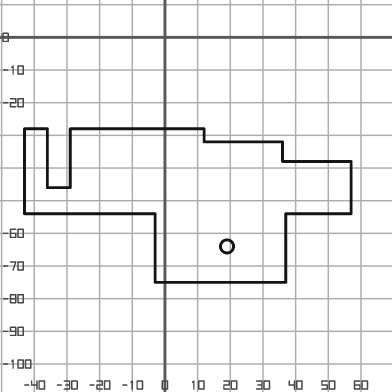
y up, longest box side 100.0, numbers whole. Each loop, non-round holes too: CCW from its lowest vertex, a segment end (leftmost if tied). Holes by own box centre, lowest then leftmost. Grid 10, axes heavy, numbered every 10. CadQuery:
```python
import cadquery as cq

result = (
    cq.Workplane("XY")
    .moveTo(-3.0, -75.0)
    .lineTo(37.0, -75.0)
    .lineTo(37.0, -54.0)
    .lineTo(57.0, -54.0)
    .lineTo(57.0, -38.0)
    .lineTo(36.0, -38.0)
    .lineTo(36.0, -32.0)
    .lineTo(12.0, -32.0)
    .lineTo(12.0, -28.0)
    .lineTo(-29.0, -28.0)
    .lineTo(-29.0, -46.0)
    .lineTo(-36.0, -46.0)
    .lineTo(-36.0, -28.0)
    .lineTo(-43.0, -28.0)
    .lineTo(-43.0, -54.0)
    .lineTo(-3.0, -54.0)
    .close()
    .moveTo(19.0, -64.0)
    .circle(2.0)
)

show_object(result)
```